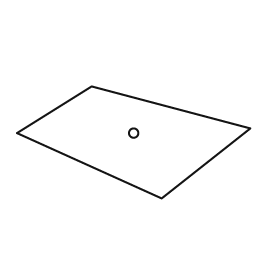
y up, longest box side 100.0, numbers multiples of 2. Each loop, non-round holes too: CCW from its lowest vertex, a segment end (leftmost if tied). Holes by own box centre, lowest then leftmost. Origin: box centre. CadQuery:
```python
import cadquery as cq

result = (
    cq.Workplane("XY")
    .moveTo(12.0, -24.0)
    .lineTo(50.0, 6.0)
    .lineTo(-18.0, 24.0)
    .lineTo(-50.0, 4.0)
    .close()
    .moveTo(0.0, 4.0)
    .circle(2.0)
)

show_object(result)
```